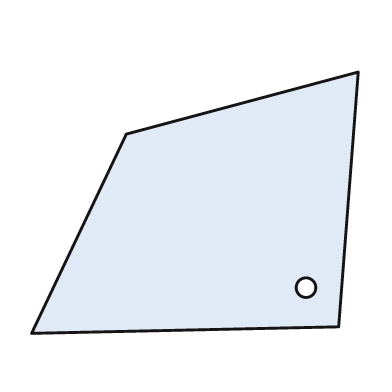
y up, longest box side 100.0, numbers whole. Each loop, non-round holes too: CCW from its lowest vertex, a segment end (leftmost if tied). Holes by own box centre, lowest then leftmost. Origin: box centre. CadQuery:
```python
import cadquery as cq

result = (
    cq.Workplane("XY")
    .moveTo(-50.0, -40.0)
    .lineTo(44.0, -38.0)
    .lineTo(50.0, 40.0)
    .lineTo(-21.0, 21.0)
    .close()
    .moveTo(34.0, -26.0)
    .circle(3.0)
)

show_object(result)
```